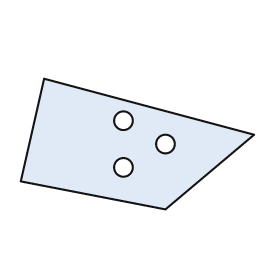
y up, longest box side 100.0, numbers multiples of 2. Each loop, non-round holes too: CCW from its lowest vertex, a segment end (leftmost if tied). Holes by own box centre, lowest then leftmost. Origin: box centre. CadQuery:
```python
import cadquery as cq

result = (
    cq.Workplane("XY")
    .moveTo(12.0, -28.0)
    .lineTo(50.0, 4.0)
    .lineTo(-40.0, 28.0)
    .lineTo(-50.0, -16.0)
    .close()
    .moveTo(-6.0, -10.0)
    .circle(4.0)
    .moveTo(12.0, 0.0)
    .circle(4.0)
    .moveTo(-6.0, 10.0)
    .circle(4.0)
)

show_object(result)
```